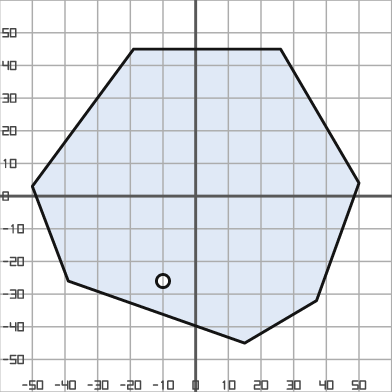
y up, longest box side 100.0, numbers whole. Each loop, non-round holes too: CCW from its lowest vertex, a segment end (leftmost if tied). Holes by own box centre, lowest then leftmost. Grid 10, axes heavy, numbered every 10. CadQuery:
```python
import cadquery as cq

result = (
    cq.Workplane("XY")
    .moveTo(15.0, -45.0)
    .lineTo(37.0, -32.0)
    .lineTo(50.0, 4.0)
    .lineTo(26.0, 45.0)
    .lineTo(-19.0, 45.0)
    .lineTo(-50.0, 3.0)
    .lineTo(-39.0, -26.0)
    .close()
    .moveTo(-10.0, -26.0)
    .circle(2.0)
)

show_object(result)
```